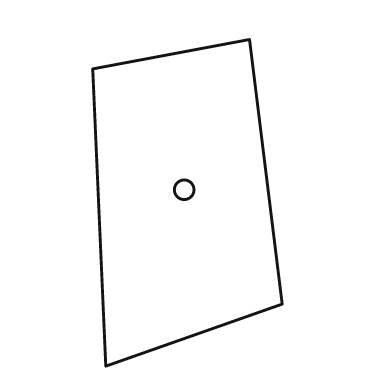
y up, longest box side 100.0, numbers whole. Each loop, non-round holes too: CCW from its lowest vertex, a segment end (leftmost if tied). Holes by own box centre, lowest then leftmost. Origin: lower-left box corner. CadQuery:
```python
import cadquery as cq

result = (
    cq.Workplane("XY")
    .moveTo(4.0, 0.0)
    .lineTo(58.0, 19.0)
    .lineTo(48.0, 100.0)
    .lineTo(0.0, 91.0)
    .close()
    .moveTo(28.0, 54.0)
    .circle(3.0)
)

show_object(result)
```